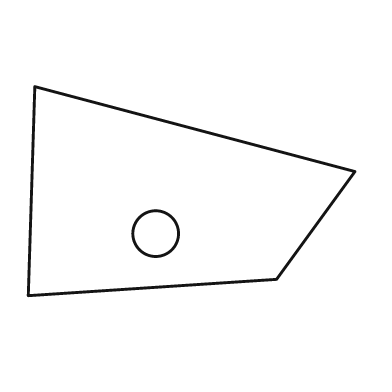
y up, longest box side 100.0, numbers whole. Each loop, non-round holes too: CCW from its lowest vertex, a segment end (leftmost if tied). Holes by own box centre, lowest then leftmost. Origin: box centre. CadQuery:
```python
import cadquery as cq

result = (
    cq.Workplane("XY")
    .moveTo(-50.0, -32.0)
    .lineTo(26.0, -27.0)
    .lineTo(50.0, 6.0)
    .lineTo(-48.0, 32.0)
    .close()
    .moveTo(-11.0, -13.0)
    .circle(7.0)
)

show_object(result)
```